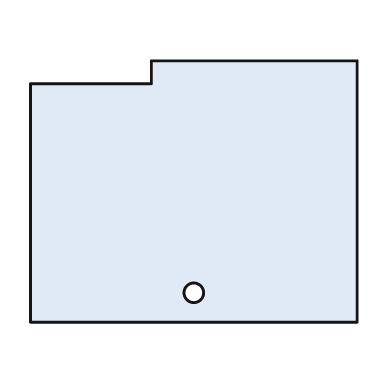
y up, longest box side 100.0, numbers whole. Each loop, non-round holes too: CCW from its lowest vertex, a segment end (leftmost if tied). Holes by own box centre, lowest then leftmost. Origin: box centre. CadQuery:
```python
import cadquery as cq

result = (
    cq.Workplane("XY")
    .moveTo(-50.0, -40.0)
    .lineTo(50.0, -40.0)
    .lineTo(50.0, 40.0)
    .lineTo(-13.0, 40.0)
    .lineTo(-13.0, 33.0)
    .lineTo(-50.0, 33.0)
    .close()
    .moveTo(0.0, -31.0)
    .circle(3.0)
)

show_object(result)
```